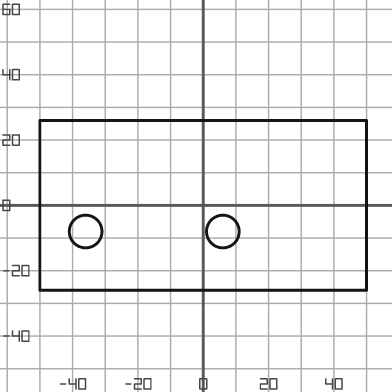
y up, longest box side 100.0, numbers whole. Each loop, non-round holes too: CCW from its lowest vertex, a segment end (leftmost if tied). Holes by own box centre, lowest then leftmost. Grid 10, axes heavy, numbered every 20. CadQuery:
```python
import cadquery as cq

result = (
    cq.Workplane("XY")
    .moveTo(-50.0, -26.0)
    .lineTo(50.0, -26.0)
    .lineTo(50.0, 26.0)
    .lineTo(-50.0, 26.0)
    .close()
    .moveTo(-36.0, -8.0)
    .circle(5.0)
    .moveTo(6.0, -8.0)
    .circle(5.0)
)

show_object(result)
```